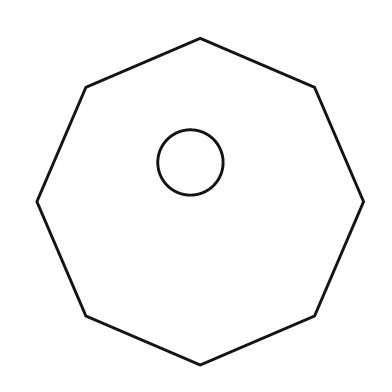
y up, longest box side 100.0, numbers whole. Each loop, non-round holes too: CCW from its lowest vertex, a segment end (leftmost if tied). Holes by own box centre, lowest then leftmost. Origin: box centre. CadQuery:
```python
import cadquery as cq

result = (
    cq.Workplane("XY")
    .moveTo(0.0, -50.0)
    .lineTo(35.0, -35.0)
    .lineTo(50.0, 0.0)
    .lineTo(35.0, 35.0)
    .lineTo(0.0, 50.0)
    .lineTo(-35.0, 35.0)
    .lineTo(-50.0, 0.0)
    .lineTo(-35.0, -35.0)
    .close()
    .moveTo(-3.0, 12.0)
    .circle(10.0)
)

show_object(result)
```